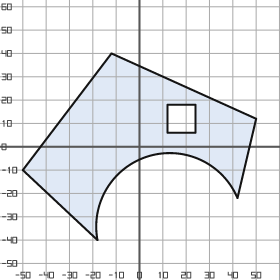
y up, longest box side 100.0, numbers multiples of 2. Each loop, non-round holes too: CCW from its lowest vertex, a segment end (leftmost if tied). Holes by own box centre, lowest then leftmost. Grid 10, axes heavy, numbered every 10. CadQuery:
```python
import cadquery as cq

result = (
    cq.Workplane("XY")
    .moveTo(-18.0, -40.0)
    .threePointArc((4.0, -4.0), (42.0, -22.0))
    .lineTo(50.0, 12.0)
    .lineTo(-12.0, 40.0)
    .lineTo(-50.0, -10.0)
    .close()
    .moveTo(12.0, 6.0)
    .lineTo(24.0, 6.0)
    .lineTo(24.0, 18.0)
    .lineTo(12.0, 18.0)
    .close()
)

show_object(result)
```